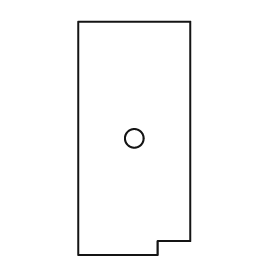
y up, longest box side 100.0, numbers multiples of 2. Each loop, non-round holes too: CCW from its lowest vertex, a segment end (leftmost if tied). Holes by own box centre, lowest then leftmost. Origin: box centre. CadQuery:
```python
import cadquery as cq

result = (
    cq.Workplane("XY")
    .moveTo(-24.0, -50.0)
    .lineTo(10.0, -50.0)
    .lineTo(10.0, -44.0)
    .lineTo(24.0, -44.0)
    .lineTo(24.0, 50.0)
    .lineTo(-24.0, 50.0)
    .close()
    .moveTo(0.0, 0.0)
    .circle(4.0)
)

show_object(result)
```